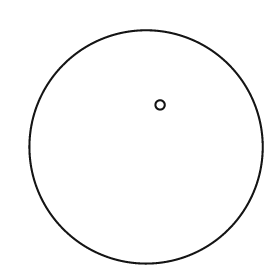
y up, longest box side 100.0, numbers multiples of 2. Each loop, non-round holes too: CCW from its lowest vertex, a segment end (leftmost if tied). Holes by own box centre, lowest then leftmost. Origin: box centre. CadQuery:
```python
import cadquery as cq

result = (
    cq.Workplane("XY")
    .moveTo(0.0, 0.0)
    .circle(50.0)
    .moveTo(6.0, 18.0)
    .circle(2.0)
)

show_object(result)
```